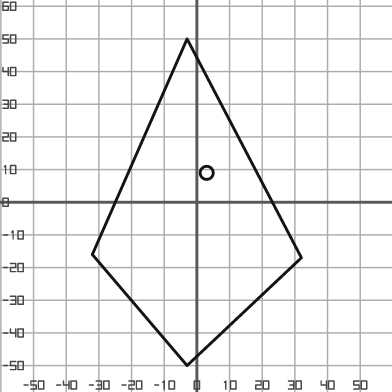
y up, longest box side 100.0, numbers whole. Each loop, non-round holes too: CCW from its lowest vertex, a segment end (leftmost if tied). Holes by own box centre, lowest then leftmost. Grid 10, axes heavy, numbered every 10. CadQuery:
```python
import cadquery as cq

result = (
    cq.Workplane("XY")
    .moveTo(-3.0, -50.0)
    .lineTo(32.0, -17.0)
    .lineTo(-3.0, 50.0)
    .lineTo(-32.0, -16.0)
    .close()
    .moveTo(3.0, 9.0)
    .circle(2.0)
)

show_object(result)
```